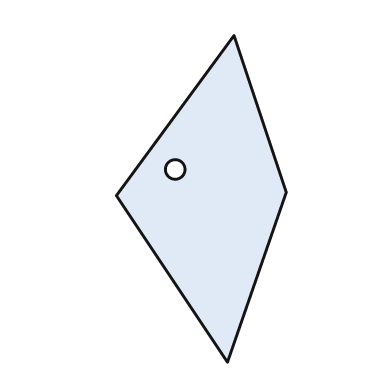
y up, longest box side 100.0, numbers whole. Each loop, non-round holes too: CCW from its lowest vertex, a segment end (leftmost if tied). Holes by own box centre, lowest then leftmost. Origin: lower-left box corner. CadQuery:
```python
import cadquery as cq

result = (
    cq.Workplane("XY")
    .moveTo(34.0, 0.0)
    .lineTo(52.0, 52.0)
    .lineTo(36.0, 100.0)
    .lineTo(0.0, 51.0)
    .close()
    .moveTo(18.0, 59.0)
    .circle(3.0)
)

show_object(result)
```